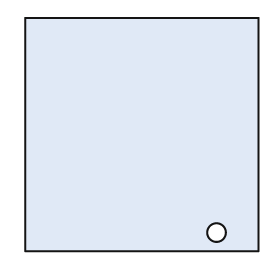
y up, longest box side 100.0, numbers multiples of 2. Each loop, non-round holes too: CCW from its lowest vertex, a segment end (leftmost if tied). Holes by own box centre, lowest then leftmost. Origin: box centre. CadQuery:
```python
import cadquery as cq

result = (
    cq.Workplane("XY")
    .moveTo(-50.0, -50.0)
    .lineTo(50.0, -50.0)
    .lineTo(50.0, 50.0)
    .lineTo(-50.0, 50.0)
    .close()
    .moveTo(32.0, -42.0)
    .circle(4.0)
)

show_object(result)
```